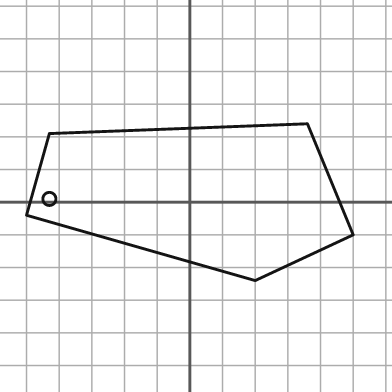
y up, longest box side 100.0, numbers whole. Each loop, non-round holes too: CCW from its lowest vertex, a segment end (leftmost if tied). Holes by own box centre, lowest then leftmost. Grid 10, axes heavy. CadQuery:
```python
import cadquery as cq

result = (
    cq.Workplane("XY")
    .moveTo(20.0, -24.0)
    .lineTo(50.0, -10.0)
    .lineTo(36.0, 24.0)
    .lineTo(-43.0, 21.0)
    .lineTo(-50.0, -4.0)
    .close()
    .moveTo(-43.0, 1.0)
    .circle(2.0)
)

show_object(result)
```